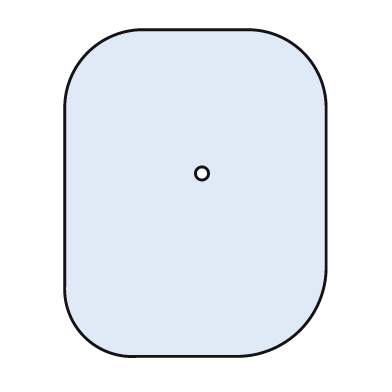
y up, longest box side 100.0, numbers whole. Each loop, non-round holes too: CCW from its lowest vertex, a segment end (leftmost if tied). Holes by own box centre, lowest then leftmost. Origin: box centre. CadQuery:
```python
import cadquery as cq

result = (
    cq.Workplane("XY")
    .moveTo(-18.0, -50.0)
    .lineTo(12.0, -50.0)
    .threePointArc((32.0, -42.0), (40.0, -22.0))
    .lineTo(40.0, 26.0)
    .threePointArc((33.0, 43.0), (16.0, 50.0))
    .lineTo(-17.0, 50.0)
    .threePointArc((-33.0, 43.0), (-40.0, 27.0))
    .lineTo(-40.0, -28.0)
    .threePointArc((-34.0, -44.0), (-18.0, -50.0))
    .close()
    .moveTo(2.0, 6.0)
    .circle(2.0)
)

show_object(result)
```